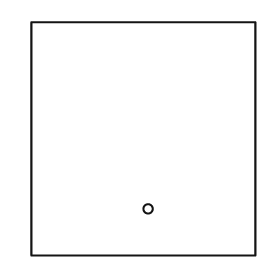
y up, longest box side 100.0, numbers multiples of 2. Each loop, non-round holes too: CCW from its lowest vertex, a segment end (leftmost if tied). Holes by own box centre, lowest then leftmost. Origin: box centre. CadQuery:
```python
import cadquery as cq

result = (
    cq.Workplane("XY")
    .moveTo(-48.0, -50.0)
    .lineTo(48.0, -50.0)
    .lineTo(48.0, 50.0)
    .lineTo(-48.0, 50.0)
    .close()
    .moveTo(2.0, -30.0)
    .circle(2.0)
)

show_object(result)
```